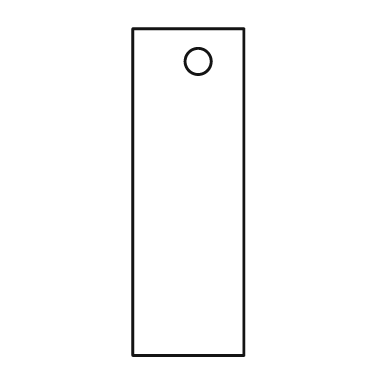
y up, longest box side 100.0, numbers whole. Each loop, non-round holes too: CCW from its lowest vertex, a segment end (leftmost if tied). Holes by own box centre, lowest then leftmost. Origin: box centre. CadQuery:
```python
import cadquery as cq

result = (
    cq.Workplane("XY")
    .moveTo(-17.0, -50.0)
    .lineTo(17.0, -50.0)
    .lineTo(17.0, 50.0)
    .lineTo(-17.0, 50.0)
    .close()
    .moveTo(3.0, 40.0)
    .circle(4.0)
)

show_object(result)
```